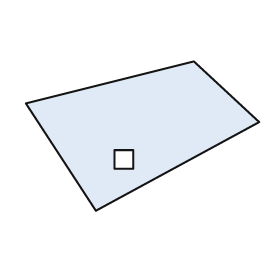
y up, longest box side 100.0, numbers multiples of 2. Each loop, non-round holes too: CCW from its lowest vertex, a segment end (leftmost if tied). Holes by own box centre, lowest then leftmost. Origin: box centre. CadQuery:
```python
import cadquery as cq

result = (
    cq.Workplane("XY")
    .moveTo(-20.0, -32.0)
    .lineTo(50.0, 6.0)
    .lineTo(22.0, 32.0)
    .lineTo(-50.0, 14.0)
    .close()
    .moveTo(-12.0, -14.0)
    .lineTo(-4.0, -14.0)
    .lineTo(-4.0, -6.0)
    .lineTo(-12.0, -6.0)
    .close()
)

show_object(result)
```